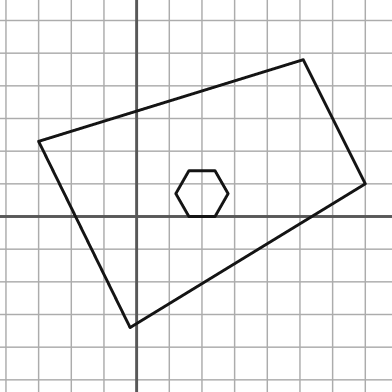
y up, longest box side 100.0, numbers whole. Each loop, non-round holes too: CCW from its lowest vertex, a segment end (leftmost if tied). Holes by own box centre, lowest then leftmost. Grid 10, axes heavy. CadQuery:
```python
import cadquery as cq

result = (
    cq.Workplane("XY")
    .moveTo(-2.0, -34.0)
    .lineTo(70.0, 10.0)
    .lineTo(51.0, 48.0)
    .lineTo(-30.0, 23.0)
    .close()
    .moveTo(16.0, 0.0)
    .lineTo(24.0, 0.0)
    .lineTo(28.0, 7.0)
    .lineTo(24.0, 14.0)
    .lineTo(16.0, 14.0)
    .lineTo(12.0, 7.0)
    .close()
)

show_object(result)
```